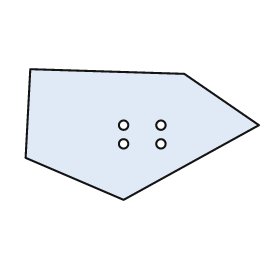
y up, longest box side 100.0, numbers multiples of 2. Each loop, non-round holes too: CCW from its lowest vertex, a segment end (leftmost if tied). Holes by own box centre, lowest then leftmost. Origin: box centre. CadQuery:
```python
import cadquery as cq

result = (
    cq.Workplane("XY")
    .moveTo(-8.0, -28.0)
    .lineTo(50.0, 4.0)
    .lineTo(18.0, 26.0)
    .lineTo(-48.0, 28.0)
    .lineTo(-50.0, -10.0)
    .close()
    .moveTo(-8.0, -4.0)
    .circle(2.0)
    .moveTo(8.0, -4.0)
    .circle(2.0)
    .moveTo(-8.0, 4.0)
    .circle(2.0)
    .moveTo(8.0, 4.0)
    .circle(2.0)
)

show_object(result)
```